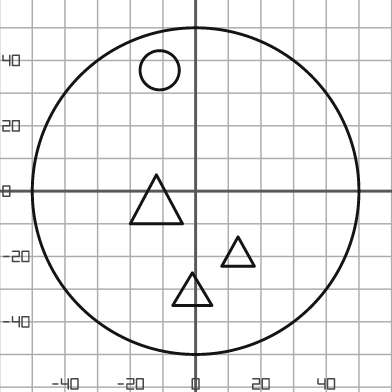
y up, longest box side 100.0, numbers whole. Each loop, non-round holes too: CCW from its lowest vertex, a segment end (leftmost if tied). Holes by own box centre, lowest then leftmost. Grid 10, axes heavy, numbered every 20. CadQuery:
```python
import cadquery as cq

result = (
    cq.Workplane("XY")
    .moveTo(0.0, 0.0)
    .circle(50.0)
    .moveTo(-7.0, -35.0)
    .lineTo(5.0, -35.0)
    .lineTo(-1.0, -25.0)
    .close()
    .moveTo(8.0, -23.0)
    .lineTo(18.0, -23.0)
    .lineTo(13.0, -14.0)
    .close()
    .moveTo(-20.0, -10.0)
    .lineTo(-4.0, -10.0)
    .lineTo(-12.0, 5.0)
    .close()
    .moveTo(-11.0, 37.0)
    .circle(6.0)
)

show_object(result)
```